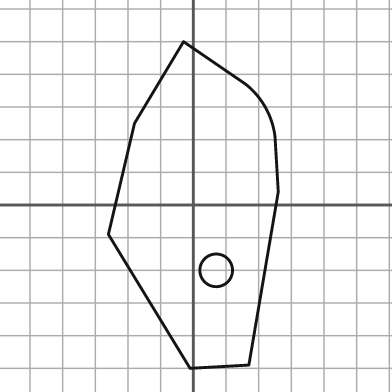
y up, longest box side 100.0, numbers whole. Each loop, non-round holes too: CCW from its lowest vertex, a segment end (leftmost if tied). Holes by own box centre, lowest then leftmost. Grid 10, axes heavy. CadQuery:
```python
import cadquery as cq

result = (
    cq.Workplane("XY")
    .moveTo(-1.0, -50.0)
    .lineTo(17.0, -49.0)
    .lineTo(26.0, 4.0)
    .lineTo(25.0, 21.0)
    .threePointArc((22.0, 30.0), (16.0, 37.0))
    .lineTo(-3.0, 50.0)
    .lineTo(-18.0, 25.0)
    .lineTo(-26.0, -9.0)
    .close()
    .moveTo(7.0, -20.0)
    .circle(5.0)
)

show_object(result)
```